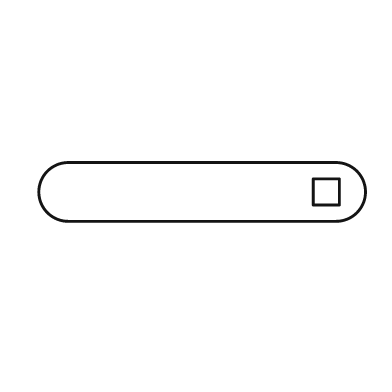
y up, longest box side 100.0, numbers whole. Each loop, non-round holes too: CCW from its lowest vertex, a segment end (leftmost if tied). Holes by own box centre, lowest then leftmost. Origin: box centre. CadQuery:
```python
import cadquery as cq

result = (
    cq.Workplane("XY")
    .moveTo(-41.0, -9.0)
    .lineTo(41.0, -9.0)
    .threePointArc((50.0, 0.0), (41.0, 9.0))
    .lineTo(-41.0, 9.0)
    .threePointArc((-50.0, 0.0), (-41.0, -9.0))
    .close()
    .moveTo(34.0, -4.0)
    .lineTo(42.0, -4.0)
    .lineTo(42.0, 4.0)
    .lineTo(34.0, 4.0)
    .close()
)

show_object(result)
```